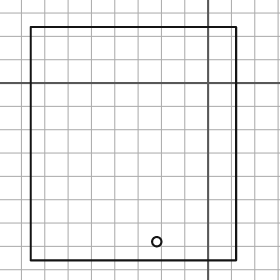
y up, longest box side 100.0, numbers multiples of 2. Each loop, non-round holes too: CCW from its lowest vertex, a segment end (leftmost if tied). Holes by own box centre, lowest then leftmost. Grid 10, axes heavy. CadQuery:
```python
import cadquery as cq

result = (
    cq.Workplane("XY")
    .moveTo(-76.0, -76.0)
    .lineTo(12.0, -76.0)
    .lineTo(12.0, 24.0)
    .lineTo(-76.0, 24.0)
    .close()
    .moveTo(-22.0, -68.0)
    .circle(2.0)
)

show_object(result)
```